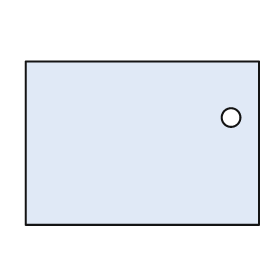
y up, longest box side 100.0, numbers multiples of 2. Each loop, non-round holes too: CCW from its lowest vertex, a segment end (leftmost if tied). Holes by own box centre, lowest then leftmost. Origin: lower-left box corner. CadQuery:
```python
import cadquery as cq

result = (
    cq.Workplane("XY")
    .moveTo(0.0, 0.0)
    .lineTo(100.0, 0.0)
    .lineTo(100.0, 70.0)
    .lineTo(0.0, 70.0)
    .close()
    .moveTo(88.0, 46.0)
    .circle(4.0)
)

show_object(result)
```